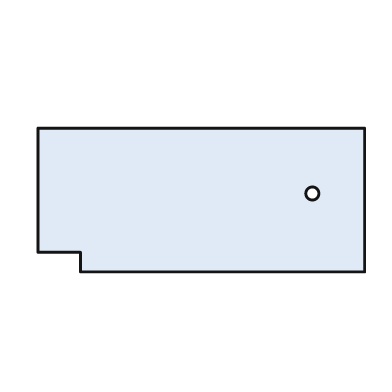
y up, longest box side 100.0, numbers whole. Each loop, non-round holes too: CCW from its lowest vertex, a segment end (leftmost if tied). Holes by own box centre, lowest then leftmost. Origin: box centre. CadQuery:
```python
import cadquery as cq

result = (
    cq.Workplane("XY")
    .moveTo(-37.0, -22.0)
    .lineTo(50.0, -22.0)
    .lineTo(50.0, 22.0)
    .lineTo(-50.0, 22.0)
    .lineTo(-50.0, -16.0)
    .lineTo(-37.0, -16.0)
    .close()
    .moveTo(34.0, 2.0)
    .circle(2.0)
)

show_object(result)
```